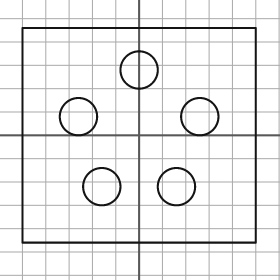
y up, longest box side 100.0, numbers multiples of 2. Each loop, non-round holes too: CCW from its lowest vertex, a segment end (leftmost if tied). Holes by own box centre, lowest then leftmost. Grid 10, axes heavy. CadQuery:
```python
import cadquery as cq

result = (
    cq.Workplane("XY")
    .moveTo(-50.0, -46.0)
    .lineTo(50.0, -46.0)
    .lineTo(50.0, 46.0)
    .lineTo(-50.0, 46.0)
    .close()
    .moveTo(-16.0, -22.0)
    .circle(8.0)
    .moveTo(16.0, -22.0)
    .circle(8.0)
    .moveTo(-26.0, 8.0)
    .circle(8.0)
    .moveTo(26.0, 8.0)
    .circle(8.0)
    .moveTo(0.0, 28.0)
    .circle(8.0)
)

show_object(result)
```